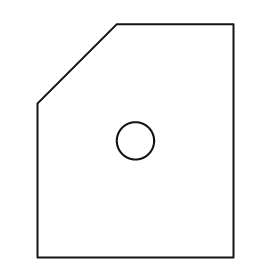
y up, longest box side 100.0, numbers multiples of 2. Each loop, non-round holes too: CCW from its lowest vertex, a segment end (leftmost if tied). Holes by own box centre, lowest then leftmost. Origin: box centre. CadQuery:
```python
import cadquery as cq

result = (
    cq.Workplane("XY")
    .moveTo(-42.0, -50.0)
    .lineTo(42.0, -50.0)
    .lineTo(42.0, 50.0)
    .lineTo(-8.0, 50.0)
    .lineTo(-42.0, 16.0)
    .close()
    .moveTo(0.0, 0.0)
    .circle(8.0)
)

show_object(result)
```